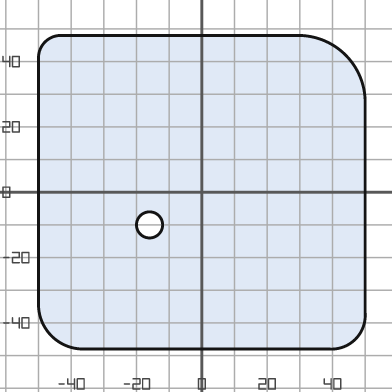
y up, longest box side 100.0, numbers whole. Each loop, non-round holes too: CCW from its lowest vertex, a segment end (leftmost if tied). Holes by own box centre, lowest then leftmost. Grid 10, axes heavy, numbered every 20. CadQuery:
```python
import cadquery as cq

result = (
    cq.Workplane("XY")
    .moveTo(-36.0, -48.0)
    .lineTo(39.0, -48.0)
    .threePointArc((47.0, -45.0), (50.0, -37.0))
    .lineTo(50.0, 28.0)
    .threePointArc((44.0, 42.0), (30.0, 48.0))
    .lineTo(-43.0, 48.0)
    .threePointArc((-48.0, 46.0), (-50.0, 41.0))
    .lineTo(-50.0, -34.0)
    .threePointArc((-46.0, -44.0), (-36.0, -48.0))
    .close()
    .moveTo(-16.0, -10.0)
    .circle(4.0)
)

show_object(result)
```